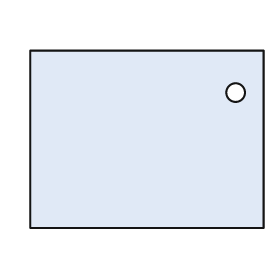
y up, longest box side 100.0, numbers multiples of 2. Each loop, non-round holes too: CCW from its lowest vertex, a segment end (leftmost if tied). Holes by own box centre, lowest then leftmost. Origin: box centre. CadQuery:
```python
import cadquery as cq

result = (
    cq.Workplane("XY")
    .moveTo(-50.0, -38.0)
    .lineTo(50.0, -38.0)
    .lineTo(50.0, 38.0)
    .lineTo(-50.0, 38.0)
    .close()
    .moveTo(38.0, 20.0)
    .circle(4.0)
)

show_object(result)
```